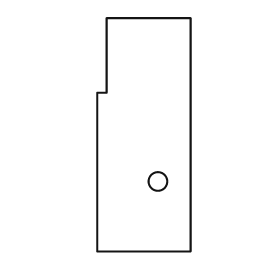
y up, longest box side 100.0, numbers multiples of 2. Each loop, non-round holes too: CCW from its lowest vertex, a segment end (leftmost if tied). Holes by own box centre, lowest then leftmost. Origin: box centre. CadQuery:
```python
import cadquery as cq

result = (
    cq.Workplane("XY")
    .moveTo(-20.0, -50.0)
    .lineTo(20.0, -50.0)
    .lineTo(20.0, 50.0)
    .lineTo(-16.0, 50.0)
    .lineTo(-16.0, 18.0)
    .lineTo(-20.0, 18.0)
    .close()
    .moveTo(6.0, -20.0)
    .circle(4.0)
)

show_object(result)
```